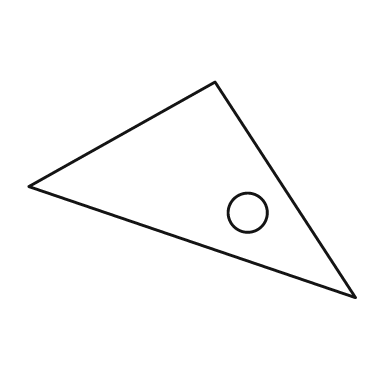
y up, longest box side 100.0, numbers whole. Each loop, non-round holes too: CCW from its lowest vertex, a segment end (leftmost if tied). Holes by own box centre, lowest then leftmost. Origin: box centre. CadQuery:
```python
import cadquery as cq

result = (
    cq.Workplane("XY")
    .moveTo(50.0, -33.0)
    .lineTo(7.0, 33.0)
    .lineTo(-50.0, 1.0)
    .close()
    .moveTo(17.0, -7.0)
    .circle(6.0)
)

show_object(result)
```